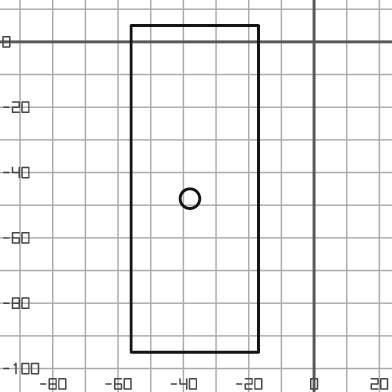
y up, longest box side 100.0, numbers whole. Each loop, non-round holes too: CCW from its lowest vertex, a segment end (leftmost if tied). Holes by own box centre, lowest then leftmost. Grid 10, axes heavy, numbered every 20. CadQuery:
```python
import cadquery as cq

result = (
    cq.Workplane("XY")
    .moveTo(-56.0, -95.0)
    .lineTo(-17.0, -95.0)
    .lineTo(-17.0, 5.0)
    .lineTo(-56.0, 5.0)
    .close()
    .moveTo(-38.0, -48.0)
    .circle(3.0)
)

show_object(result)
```